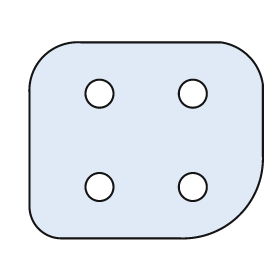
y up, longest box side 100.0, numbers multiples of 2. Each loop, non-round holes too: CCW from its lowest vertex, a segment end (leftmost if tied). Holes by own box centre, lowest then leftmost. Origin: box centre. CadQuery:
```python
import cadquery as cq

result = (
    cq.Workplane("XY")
    .moveTo(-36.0, -42.0)
    .lineTo(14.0, -42.0)
    .threePointArc((40.0, -32.0), (50.0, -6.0))
    .lineTo(50.0, 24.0)
    .threePointArc((44.0, 36.0), (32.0, 42.0))
    .lineTo(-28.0, 42.0)
    .threePointArc((-44.0, 36.0), (-50.0, 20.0))
    .lineTo(-50.0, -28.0)
    .threePointArc((-46.0, -38.0), (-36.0, -42.0))
    .close()
    .moveTo(-20.0, -20.0)
    .circle(6.0)
    .moveTo(20.0, -20.0)
    .circle(6.0)
    .moveTo(-20.0, 20.0)
    .circle(6.0)
    .moveTo(20.0, 20.0)
    .circle(6.0)
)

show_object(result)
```